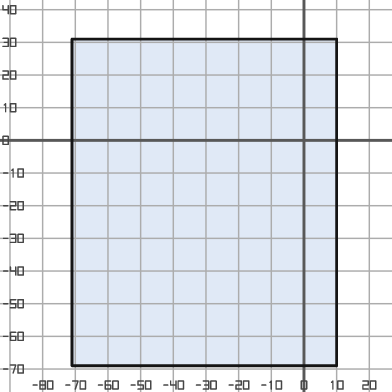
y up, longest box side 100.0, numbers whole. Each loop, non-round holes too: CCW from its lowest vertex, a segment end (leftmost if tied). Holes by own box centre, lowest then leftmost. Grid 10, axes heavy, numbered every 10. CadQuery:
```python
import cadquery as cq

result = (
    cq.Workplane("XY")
    .moveTo(-71.0, -69.0)
    .lineTo(10.0, -69.0)
    .lineTo(10.0, 31.0)
    .lineTo(-71.0, 31.0)
    .close()
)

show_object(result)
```